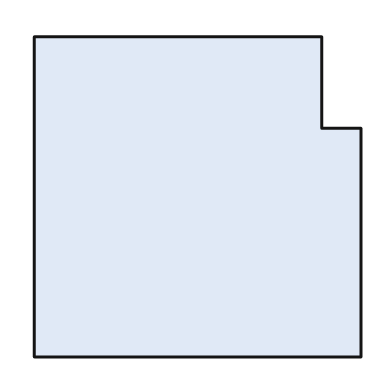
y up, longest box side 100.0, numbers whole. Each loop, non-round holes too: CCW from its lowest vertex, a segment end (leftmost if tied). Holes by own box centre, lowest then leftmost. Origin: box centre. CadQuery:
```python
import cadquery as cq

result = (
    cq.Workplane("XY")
    .moveTo(-50.0, -49.0)
    .lineTo(50.0, -49.0)
    .lineTo(50.0, 21.0)
    .lineTo(38.0, 21.0)
    .lineTo(38.0, 49.0)
    .lineTo(-50.0, 49.0)
    .close()
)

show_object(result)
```